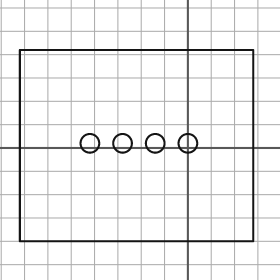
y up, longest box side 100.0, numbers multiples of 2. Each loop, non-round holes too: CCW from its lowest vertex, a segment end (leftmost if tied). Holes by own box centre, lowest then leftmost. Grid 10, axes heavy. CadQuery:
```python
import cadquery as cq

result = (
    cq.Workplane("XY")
    .moveTo(-72.0, -40.0)
    .lineTo(28.0, -40.0)
    .lineTo(28.0, 42.0)
    .lineTo(-72.0, 42.0)
    .close()
    .moveTo(-42.0, 2.0)
    .circle(4.0)
    .moveTo(-28.0, 2.0)
    .circle(4.0)
    .moveTo(-14.0, 2.0)
    .circle(4.0)
    .moveTo(0.0, 2.0)
    .circle(4.0)
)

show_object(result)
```